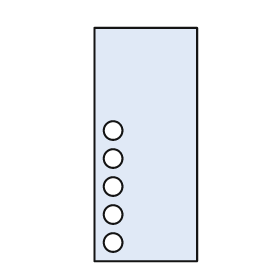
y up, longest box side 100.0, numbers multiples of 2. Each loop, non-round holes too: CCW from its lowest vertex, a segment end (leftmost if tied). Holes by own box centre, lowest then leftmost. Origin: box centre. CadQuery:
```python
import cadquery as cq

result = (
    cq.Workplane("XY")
    .moveTo(-22.0, -50.0)
    .lineTo(22.0, -50.0)
    .lineTo(22.0, 50.0)
    .lineTo(-22.0, 50.0)
    .close()
    .moveTo(-14.0, -42.0)
    .circle(4.0)
    .moveTo(-14.0, -30.0)
    .circle(4.0)
    .moveTo(-14.0, -18.0)
    .circle(4.0)
    .moveTo(-14.0, -6.0)
    .circle(4.0)
    .moveTo(-14.0, 6.0)
    .circle(4.0)
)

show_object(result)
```